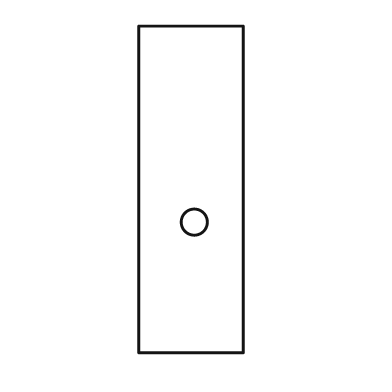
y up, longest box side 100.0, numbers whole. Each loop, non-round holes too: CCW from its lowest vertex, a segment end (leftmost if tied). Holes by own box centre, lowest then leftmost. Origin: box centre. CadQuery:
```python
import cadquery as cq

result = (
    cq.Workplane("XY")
    .moveTo(-16.0, -50.0)
    .lineTo(16.0, -50.0)
    .lineTo(16.0, 50.0)
    .lineTo(-16.0, 50.0)
    .close()
    .moveTo(1.0, -10.0)
    .circle(4.0)
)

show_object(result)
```